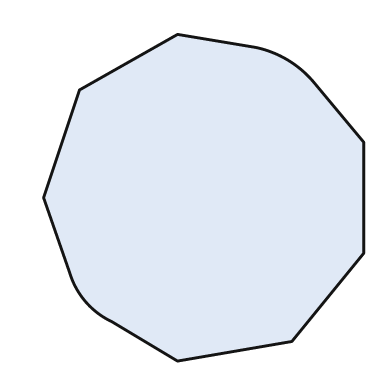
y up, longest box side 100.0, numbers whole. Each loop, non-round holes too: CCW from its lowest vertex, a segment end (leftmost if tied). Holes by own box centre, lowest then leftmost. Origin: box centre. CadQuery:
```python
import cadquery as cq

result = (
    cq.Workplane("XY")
    .moveTo(-8.0, -50.0)
    .lineTo(27.0, -44.0)
    .lineTo(49.0, -17.0)
    .lineTo(49.0, 17.0)
    .lineTo(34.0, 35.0)
    .threePointArc((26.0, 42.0), (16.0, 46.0))
    .lineTo(-8.0, 50.0)
    .lineTo(-38.0, 33.0)
    .lineTo(-49.0, 0.0)
    .lineTo(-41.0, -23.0)
    .threePointArc((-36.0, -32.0), (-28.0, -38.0))
    .close()
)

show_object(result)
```